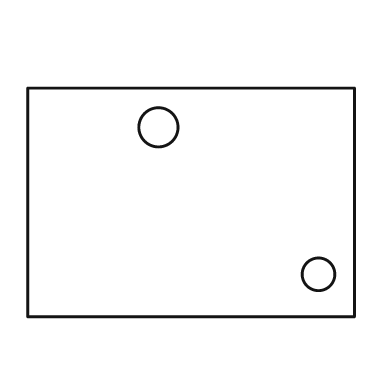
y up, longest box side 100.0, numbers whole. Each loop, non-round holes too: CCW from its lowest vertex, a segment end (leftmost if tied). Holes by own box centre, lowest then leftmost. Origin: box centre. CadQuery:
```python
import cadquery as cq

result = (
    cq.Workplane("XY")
    .moveTo(-50.0, -35.0)
    .lineTo(50.0, -35.0)
    .lineTo(50.0, 35.0)
    .lineTo(-50.0, 35.0)
    .close()
    .moveTo(39.0, -22.0)
    .circle(5.0)
    .moveTo(-10.0, 23.0)
    .circle(6.0)
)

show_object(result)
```